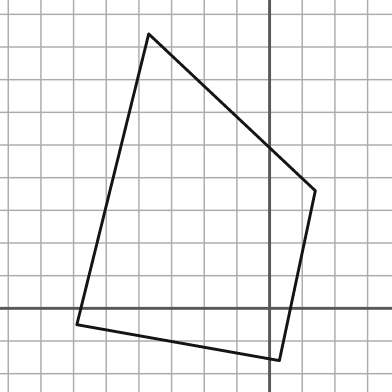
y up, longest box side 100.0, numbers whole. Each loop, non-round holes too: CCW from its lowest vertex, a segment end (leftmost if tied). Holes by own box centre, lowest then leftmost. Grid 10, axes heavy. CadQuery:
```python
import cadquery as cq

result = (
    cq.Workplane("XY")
    .moveTo(3.0, -16.0)
    .lineTo(14.0, 36.0)
    .lineTo(-37.0, 84.0)
    .lineTo(-59.0, -5.0)
    .close()
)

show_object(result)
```